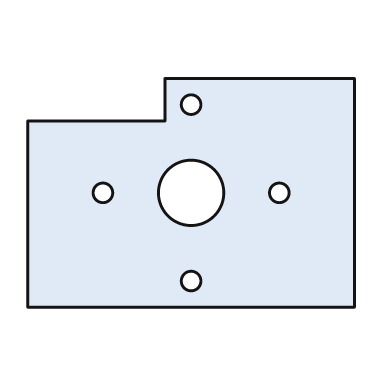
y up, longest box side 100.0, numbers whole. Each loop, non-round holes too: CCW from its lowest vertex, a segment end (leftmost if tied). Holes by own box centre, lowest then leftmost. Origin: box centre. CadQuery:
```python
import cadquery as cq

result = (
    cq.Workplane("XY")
    .moveTo(-50.0, -35.0)
    .lineTo(50.0, -35.0)
    .lineTo(50.0, 35.0)
    .lineTo(-8.0, 35.0)
    .lineTo(-8.0, 22.0)
    .lineTo(-50.0, 22.0)
    .close()
    .moveTo(0.0, -27.0)
    .circle(3.0)
    .moveTo(-27.0, 0.0)
    .circle(3.0)
    .moveTo(0.0, 0.0)
    .circle(10.0)
    .moveTo(27.0, 0.0)
    .circle(3.0)
    .moveTo(0.0, 27.0)
    .circle(3.0)
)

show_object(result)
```